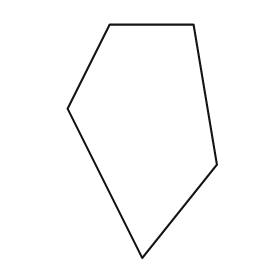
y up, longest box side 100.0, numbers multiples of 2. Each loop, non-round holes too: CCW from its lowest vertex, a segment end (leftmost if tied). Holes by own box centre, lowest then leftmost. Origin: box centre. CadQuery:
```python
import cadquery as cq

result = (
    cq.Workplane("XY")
    .moveTo(0.0, -50.0)
    .lineTo(32.0, -10.0)
    .lineTo(22.0, 50.0)
    .lineTo(-14.0, 50.0)
    .lineTo(-32.0, 14.0)
    .close()
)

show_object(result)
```